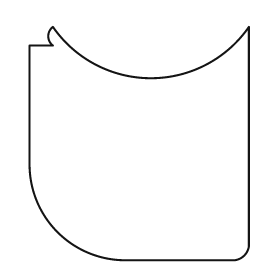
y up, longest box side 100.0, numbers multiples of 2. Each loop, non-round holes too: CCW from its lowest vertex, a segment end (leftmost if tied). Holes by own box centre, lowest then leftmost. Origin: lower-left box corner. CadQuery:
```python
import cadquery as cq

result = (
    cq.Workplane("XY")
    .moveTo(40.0, 0.0)
    .lineTo(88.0, 0.0)
    .threePointArc((92.0, 2.0), (94.0, 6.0))
    .lineTo(94.0, 100.0)
    .threePointArc((52.0, 78.0), (10.0, 100.0))
    .threePointArc((8.0, 96.0), (10.0, 92.0))
    .lineTo(0.0, 92.0)
    .lineTo(0.0, 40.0)
    .threePointArc((12.0, 12.0), (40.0, 0.0))
    .close()
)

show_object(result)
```